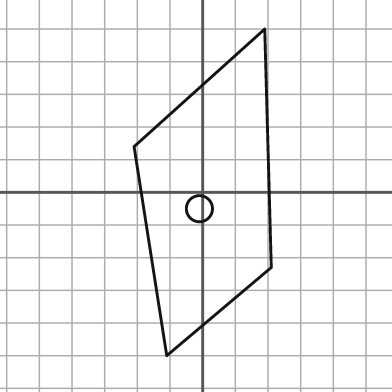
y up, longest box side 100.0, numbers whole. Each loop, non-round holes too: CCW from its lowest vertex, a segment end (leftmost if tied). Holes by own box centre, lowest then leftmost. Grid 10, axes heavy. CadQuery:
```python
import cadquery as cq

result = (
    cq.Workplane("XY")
    .moveTo(-11.0, -50.0)
    .lineTo(21.0, -23.0)
    .lineTo(19.0, 50.0)
    .lineTo(-21.0, 14.0)
    .close()
    .moveTo(-1.0, -5.0)
    .circle(4.0)
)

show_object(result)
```